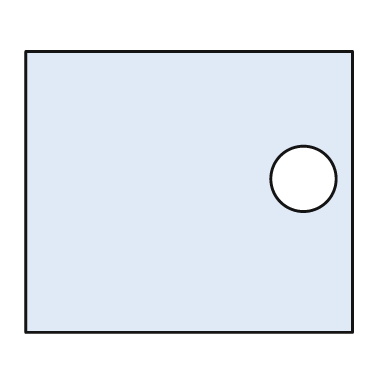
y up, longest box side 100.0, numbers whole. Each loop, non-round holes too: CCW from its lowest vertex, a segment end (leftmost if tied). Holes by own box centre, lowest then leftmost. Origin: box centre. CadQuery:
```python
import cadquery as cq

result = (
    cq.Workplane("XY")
    .moveTo(-50.0, -43.0)
    .lineTo(50.0, -43.0)
    .lineTo(50.0, 43.0)
    .lineTo(-50.0, 43.0)
    .close()
    .moveTo(35.0, 4.0)
    .circle(10.0)
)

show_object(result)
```